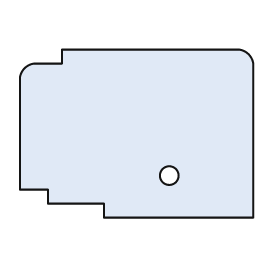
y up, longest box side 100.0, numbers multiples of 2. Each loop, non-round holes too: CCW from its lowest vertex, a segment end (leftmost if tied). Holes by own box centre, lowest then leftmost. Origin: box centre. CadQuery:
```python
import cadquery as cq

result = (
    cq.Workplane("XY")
    .moveTo(-14.0, -36.0)
    .lineTo(50.0, -36.0)
    .lineTo(50.0, 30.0)
    .threePointArc((48.0, 34.0), (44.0, 36.0))
    .lineTo(-32.0, 36.0)
    .lineTo(-32.0, 30.0)
    .lineTo(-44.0, 30.0)
    .threePointArc((-48.0, 28.0), (-50.0, 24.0))
    .lineTo(-50.0, -24.0)
    .lineTo(-38.0, -24.0)
    .lineTo(-38.0, -30.0)
    .lineTo(-14.0, -30.0)
    .close()
    .moveTo(14.0, -18.0)
    .circle(4.0)
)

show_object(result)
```